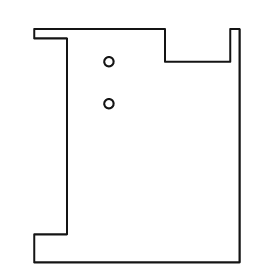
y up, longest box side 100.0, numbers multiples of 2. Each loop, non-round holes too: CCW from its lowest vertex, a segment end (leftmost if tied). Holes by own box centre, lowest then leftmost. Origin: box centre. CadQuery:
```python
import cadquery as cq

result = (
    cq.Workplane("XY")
    .moveTo(-44.0, -50.0)
    .lineTo(44.0, -50.0)
    .lineTo(44.0, 50.0)
    .lineTo(40.0, 50.0)
    .lineTo(40.0, 36.0)
    .lineTo(12.0, 36.0)
    .lineTo(12.0, 50.0)
    .lineTo(-44.0, 50.0)
    .lineTo(-44.0, 46.0)
    .lineTo(-30.0, 46.0)
    .lineTo(-30.0, -38.0)
    .lineTo(-44.0, -38.0)
    .close()
    .moveTo(-12.0, 18.0)
    .circle(2.0)
    .moveTo(-12.0, 36.0)
    .circle(2.0)
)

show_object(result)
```